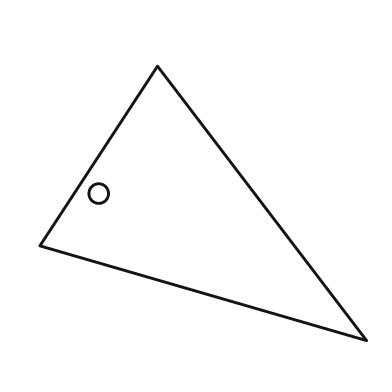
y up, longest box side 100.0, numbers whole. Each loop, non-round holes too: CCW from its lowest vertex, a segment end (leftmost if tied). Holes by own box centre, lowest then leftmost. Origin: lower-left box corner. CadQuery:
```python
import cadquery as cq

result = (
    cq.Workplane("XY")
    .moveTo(100.0, 0.0)
    .lineTo(36.0, 84.0)
    .lineTo(0.0, 29.0)
    .close()
    .moveTo(18.0, 45.0)
    .circle(3.0)
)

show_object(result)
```